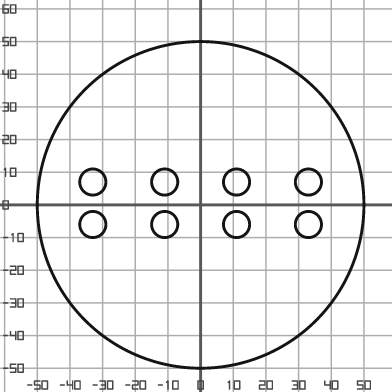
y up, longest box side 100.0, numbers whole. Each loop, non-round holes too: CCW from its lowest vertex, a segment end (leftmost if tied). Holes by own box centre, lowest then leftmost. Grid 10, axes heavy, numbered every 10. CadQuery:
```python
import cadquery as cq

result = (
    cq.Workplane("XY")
    .moveTo(0.0, 0.0)
    .circle(50.0)
    .moveTo(-33.0, -6.0)
    .circle(4.0)
    .moveTo(-11.0, -6.0)
    .circle(4.0)
    .moveTo(11.0, -6.0)
    .circle(4.0)
    .moveTo(33.0, -6.0)
    .circle(4.0)
    .moveTo(-33.0, 7.0)
    .circle(4.0)
    .moveTo(-11.0, 7.0)
    .circle(4.0)
    .moveTo(11.0, 7.0)
    .circle(4.0)
    .moveTo(33.0, 7.0)
    .circle(4.0)
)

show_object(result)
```